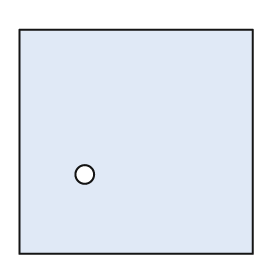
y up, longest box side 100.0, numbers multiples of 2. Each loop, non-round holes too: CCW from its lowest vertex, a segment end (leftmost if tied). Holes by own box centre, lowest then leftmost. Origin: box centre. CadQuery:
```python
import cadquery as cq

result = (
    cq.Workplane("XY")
    .moveTo(-50.0, -48.0)
    .lineTo(50.0, -48.0)
    .lineTo(50.0, 48.0)
    .lineTo(-50.0, 48.0)
    .close()
    .moveTo(-22.0, -14.0)
    .circle(4.0)
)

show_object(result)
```